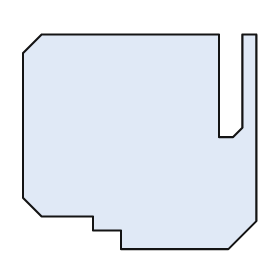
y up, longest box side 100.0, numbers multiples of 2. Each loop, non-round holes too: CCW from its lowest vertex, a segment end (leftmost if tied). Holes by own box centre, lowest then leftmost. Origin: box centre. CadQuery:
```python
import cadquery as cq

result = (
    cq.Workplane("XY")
    .moveTo(-8.0, -46.0)
    .lineTo(38.0, -46.0)
    .lineTo(50.0, -34.0)
    .lineTo(50.0, 46.0)
    .lineTo(44.0, 46.0)
    .lineTo(44.0, 6.0)
    .lineTo(40.0, 2.0)
    .lineTo(34.0, 2.0)
    .lineTo(34.0, 46.0)
    .lineTo(-42.0, 46.0)
    .lineTo(-50.0, 38.0)
    .lineTo(-50.0, -24.0)
    .lineTo(-42.0, -32.0)
    .lineTo(-20.0, -32.0)
    .lineTo(-20.0, -38.0)
    .lineTo(-8.0, -38.0)
    .close()
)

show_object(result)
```